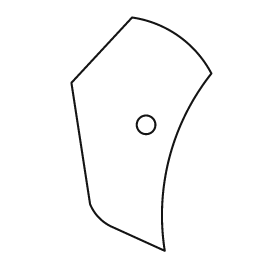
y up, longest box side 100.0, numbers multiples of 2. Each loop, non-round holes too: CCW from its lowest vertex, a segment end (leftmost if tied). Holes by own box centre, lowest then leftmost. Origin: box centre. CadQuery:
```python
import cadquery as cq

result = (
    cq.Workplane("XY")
    .moveTo(10.0, -50.0)
    .threePointArc((12.0, -10.0), (30.0, 26.0))
    .threePointArc((16.0, 42.0), (-4.0, 50.0))
    .lineTo(-30.0, 22.0)
    .lineTo(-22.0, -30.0)
    .threePointArc((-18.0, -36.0), (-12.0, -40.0))
    .close()
    .moveTo(2.0, 4.0)
    .circle(4.0)
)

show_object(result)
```